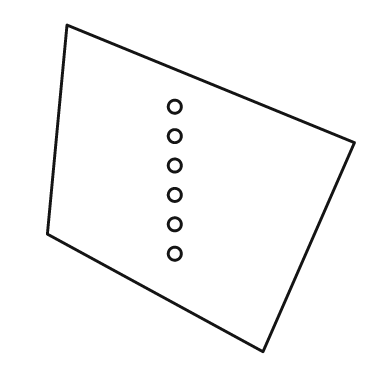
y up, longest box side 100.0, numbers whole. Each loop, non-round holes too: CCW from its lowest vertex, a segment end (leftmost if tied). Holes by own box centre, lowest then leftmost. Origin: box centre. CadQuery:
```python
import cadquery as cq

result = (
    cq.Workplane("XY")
    .moveTo(19.0, -50.0)
    .lineTo(47.0, 14.0)
    .lineTo(-41.0, 50.0)
    .lineTo(-47.0, -14.0)
    .close()
    .moveTo(-8.0, -20.0)
    .circle(2.0)
    .moveTo(-8.0, -11.0)
    .circle(2.0)
    .moveTo(-8.0, -2.0)
    .circle(2.0)
    .moveTo(-8.0, 7.0)
    .circle(2.0)
    .moveTo(-8.0, 16.0)
    .circle(2.0)
    .moveTo(-8.0, 25.0)
    .circle(2.0)
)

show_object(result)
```